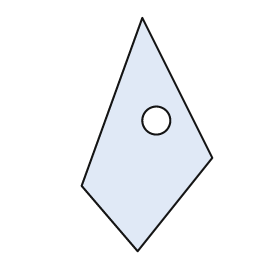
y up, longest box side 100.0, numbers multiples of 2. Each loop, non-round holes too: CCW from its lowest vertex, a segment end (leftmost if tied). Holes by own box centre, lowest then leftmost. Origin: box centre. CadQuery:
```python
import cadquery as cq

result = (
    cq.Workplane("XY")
    .moveTo(-4.0, -50.0)
    .lineTo(28.0, -10.0)
    .lineTo(-2.0, 50.0)
    .lineTo(-28.0, -22.0)
    .close()
    .moveTo(4.0, 6.0)
    .circle(6.0)
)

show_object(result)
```